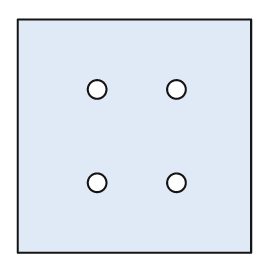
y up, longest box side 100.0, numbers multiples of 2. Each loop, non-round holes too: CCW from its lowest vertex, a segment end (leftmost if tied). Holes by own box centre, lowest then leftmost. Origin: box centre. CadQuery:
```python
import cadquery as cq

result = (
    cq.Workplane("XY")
    .moveTo(-50.0, -50.0)
    .lineTo(50.0, -50.0)
    .lineTo(50.0, 50.0)
    .lineTo(-50.0, 50.0)
    .close()
    .moveTo(-16.0, -20.0)
    .circle(4.0)
    .moveTo(18.0, -20.0)
    .circle(4.0)
    .moveTo(-16.0, 20.0)
    .circle(4.0)
    .moveTo(18.0, 20.0)
    .circle(4.0)
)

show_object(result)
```